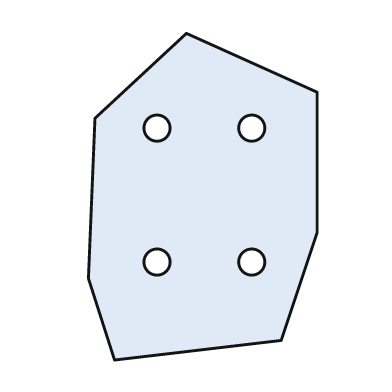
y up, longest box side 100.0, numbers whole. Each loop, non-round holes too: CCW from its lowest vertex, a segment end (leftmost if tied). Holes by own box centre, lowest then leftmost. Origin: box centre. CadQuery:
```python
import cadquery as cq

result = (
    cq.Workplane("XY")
    .moveTo(-27.0, -50.0)
    .lineTo(24.0, -44.0)
    .lineTo(35.0, -11.0)
    .lineTo(35.0, 32.0)
    .lineTo(-5.0, 50.0)
    .lineTo(-33.0, 24.0)
    .lineTo(-35.0, -25.0)
    .close()
    .moveTo(-14.0, -20.0)
    .circle(4.0)
    .moveTo(15.0, -20.0)
    .circle(4.0)
    .moveTo(-14.0, 21.0)
    .circle(4.0)
    .moveTo(15.0, 21.0)
    .circle(4.0)
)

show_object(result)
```